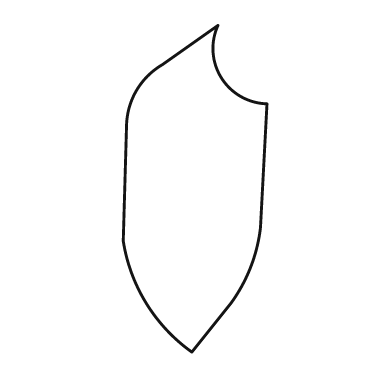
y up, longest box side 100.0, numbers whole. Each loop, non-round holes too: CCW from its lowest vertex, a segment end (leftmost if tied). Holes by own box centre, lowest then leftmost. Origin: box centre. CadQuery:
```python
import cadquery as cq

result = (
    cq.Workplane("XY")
    .moveTo(-1.0, -50.0)
    .lineTo(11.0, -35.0)
    .threePointArc((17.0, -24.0), (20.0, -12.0))
    .lineTo(22.0, 26.0)
    .threePointArc((8.0, 34.0), (7.0, 50.0))
    .lineTo(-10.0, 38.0)
    .threePointArc((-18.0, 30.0), (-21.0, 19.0))
    .lineTo(-22.0, -16.0)
    .threePointArc((-15.0, -35.0), (-1.0, -50.0))
    .close()
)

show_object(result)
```